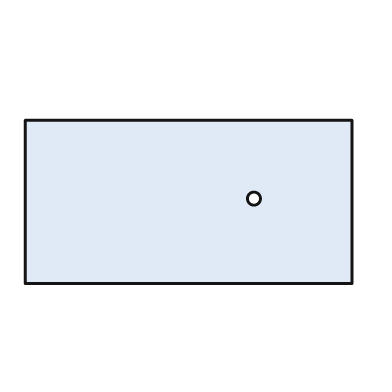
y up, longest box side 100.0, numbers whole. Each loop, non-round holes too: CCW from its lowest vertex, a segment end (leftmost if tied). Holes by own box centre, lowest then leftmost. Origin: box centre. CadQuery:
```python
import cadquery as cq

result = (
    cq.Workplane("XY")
    .moveTo(-50.0, -25.0)
    .lineTo(50.0, -25.0)
    .lineTo(50.0, 25.0)
    .lineTo(-50.0, 25.0)
    .close()
    .moveTo(20.0, 1.0)
    .circle(2.0)
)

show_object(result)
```